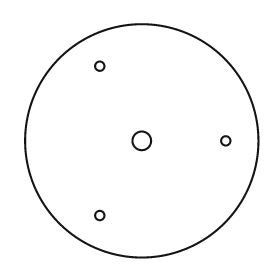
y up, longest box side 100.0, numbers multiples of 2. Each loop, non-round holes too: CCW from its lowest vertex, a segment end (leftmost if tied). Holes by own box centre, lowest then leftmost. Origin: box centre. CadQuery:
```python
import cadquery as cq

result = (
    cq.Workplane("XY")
    .moveTo(0.0, 0.0)
    .circle(50.0)
    .moveTo(-18.0, -32.0)
    .circle(2.0)
    .moveTo(0.0, 0.0)
    .circle(4.0)
    .moveTo(36.0, 0.0)
    .circle(2.0)
    .moveTo(-18.0, 32.0)
    .circle(2.0)
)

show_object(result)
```